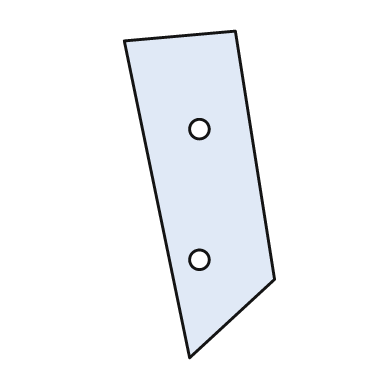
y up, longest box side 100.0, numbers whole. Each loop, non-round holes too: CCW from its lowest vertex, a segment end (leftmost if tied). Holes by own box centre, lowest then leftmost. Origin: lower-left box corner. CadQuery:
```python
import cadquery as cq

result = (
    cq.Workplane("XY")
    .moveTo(20.0, 0.0)
    .lineTo(46.0, 24.0)
    .lineTo(34.0, 100.0)
    .lineTo(0.0, 97.0)
    .close()
    .moveTo(23.0, 30.0)
    .circle(3.0)
    .moveTo(23.0, 70.0)
    .circle(3.0)
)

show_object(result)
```